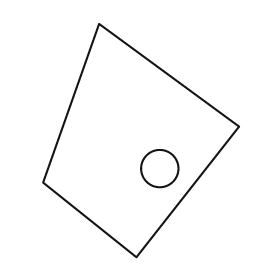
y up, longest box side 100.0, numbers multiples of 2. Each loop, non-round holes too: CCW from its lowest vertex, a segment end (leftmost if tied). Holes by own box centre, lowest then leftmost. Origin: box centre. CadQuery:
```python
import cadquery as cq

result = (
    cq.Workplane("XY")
    .moveTo(-2.0, -50.0)
    .lineTo(42.0, 6.0)
    .lineTo(-18.0, 50.0)
    .lineTo(-42.0, -18.0)
    .close()
    .moveTo(8.0, -12.0)
    .circle(8.0)
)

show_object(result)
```